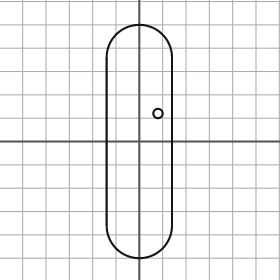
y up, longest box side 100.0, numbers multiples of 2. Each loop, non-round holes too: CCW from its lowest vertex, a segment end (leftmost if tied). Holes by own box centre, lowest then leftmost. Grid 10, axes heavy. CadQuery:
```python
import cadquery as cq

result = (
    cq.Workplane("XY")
    .moveTo(-14.0, -36.0)
    .threePointArc((0.0, -50.0), (14.0, -36.0))
    .lineTo(14.0, 36.0)
    .threePointArc((0.0, 50.0), (-14.0, 36.0))
    .close()
    .moveTo(8.0, 12.0)
    .circle(2.0)
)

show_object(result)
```